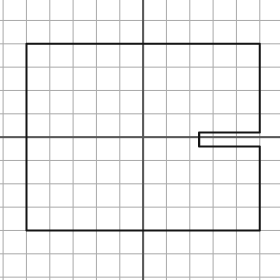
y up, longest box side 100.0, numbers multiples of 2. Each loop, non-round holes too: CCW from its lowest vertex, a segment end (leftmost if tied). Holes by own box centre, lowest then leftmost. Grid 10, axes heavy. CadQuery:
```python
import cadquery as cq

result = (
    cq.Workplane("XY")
    .moveTo(-50.0, -40.0)
    .lineTo(50.0, -40.0)
    .lineTo(50.0, -4.0)
    .lineTo(24.0, -4.0)
    .lineTo(24.0, 2.0)
    .lineTo(50.0, 2.0)
    .lineTo(50.0, 40.0)
    .lineTo(-50.0, 40.0)
    .close()
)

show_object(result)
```